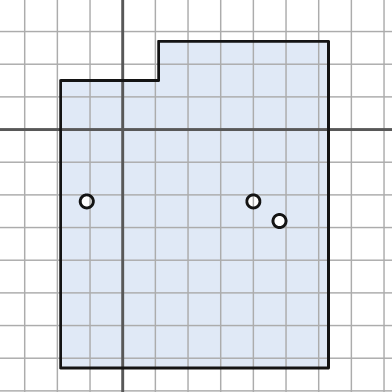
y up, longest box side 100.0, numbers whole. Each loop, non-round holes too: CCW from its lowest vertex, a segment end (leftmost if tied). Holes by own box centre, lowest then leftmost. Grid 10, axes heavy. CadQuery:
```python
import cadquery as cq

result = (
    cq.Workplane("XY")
    .moveTo(-19.0, -73.0)
    .lineTo(63.0, -73.0)
    .lineTo(63.0, 27.0)
    .lineTo(11.0, 27.0)
    .lineTo(11.0, 15.0)
    .lineTo(-19.0, 15.0)
    .close()
    .moveTo(48.0, -28.0)
    .circle(2.0)
    .moveTo(-11.0, -22.0)
    .circle(2.0)
    .moveTo(40.0, -22.0)
    .circle(2.0)
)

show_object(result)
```